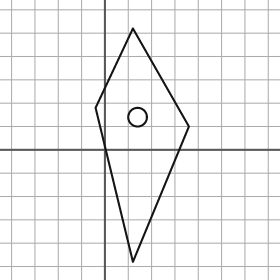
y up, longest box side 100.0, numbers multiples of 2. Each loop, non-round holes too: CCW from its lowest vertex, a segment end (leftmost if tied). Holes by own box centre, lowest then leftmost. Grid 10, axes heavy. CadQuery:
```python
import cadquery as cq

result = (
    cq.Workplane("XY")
    .moveTo(12.0, -48.0)
    .lineTo(36.0, 10.0)
    .lineTo(12.0, 52.0)
    .lineTo(-4.0, 18.0)
    .close()
    .moveTo(14.0, 14.0)
    .circle(4.0)
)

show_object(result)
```